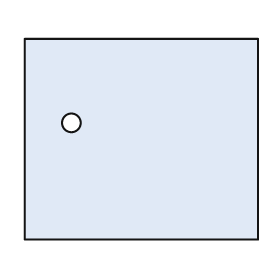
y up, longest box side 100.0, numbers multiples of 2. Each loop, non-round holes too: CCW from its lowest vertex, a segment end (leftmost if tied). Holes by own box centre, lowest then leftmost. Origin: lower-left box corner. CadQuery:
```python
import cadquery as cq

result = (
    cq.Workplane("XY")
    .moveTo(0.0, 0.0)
    .lineTo(100.0, 0.0)
    .lineTo(100.0, 86.0)
    .lineTo(0.0, 86.0)
    .close()
    .moveTo(20.0, 50.0)
    .circle(4.0)
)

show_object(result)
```